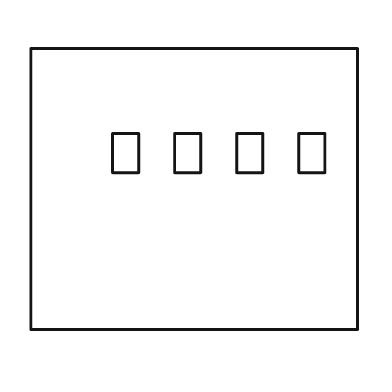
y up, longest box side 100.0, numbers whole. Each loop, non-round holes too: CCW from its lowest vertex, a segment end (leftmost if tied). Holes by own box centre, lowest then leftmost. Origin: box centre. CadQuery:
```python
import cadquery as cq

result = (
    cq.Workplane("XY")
    .moveTo(-50.0, -43.0)
    .lineTo(50.0, -43.0)
    .lineTo(50.0, 43.0)
    .lineTo(-50.0, 43.0)
    .close()
    .moveTo(-25.0, 5.0)
    .lineTo(-17.0, 5.0)
    .lineTo(-17.0, 17.0)
    .lineTo(-25.0, 17.0)
    .close()
    .moveTo(-6.0, 5.0)
    .lineTo(2.0, 5.0)
    .lineTo(2.0, 17.0)
    .lineTo(-6.0, 17.0)
    .close()
    .moveTo(13.0, 5.0)
    .lineTo(21.0, 5.0)
    .lineTo(21.0, 17.0)
    .lineTo(13.0, 17.0)
    .close()
    .moveTo(32.0, 5.0)
    .lineTo(40.0, 5.0)
    .lineTo(40.0, 17.0)
    .lineTo(32.0, 17.0)
    .close()
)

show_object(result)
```